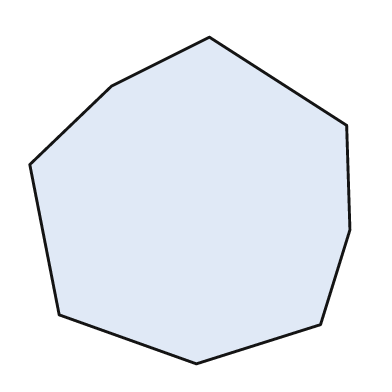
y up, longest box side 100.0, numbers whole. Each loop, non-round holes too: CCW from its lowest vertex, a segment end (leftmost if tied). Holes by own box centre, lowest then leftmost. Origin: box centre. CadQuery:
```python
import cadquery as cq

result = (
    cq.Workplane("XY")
    .moveTo(2.0, -50.0)
    .lineTo(40.0, -38.0)
    .lineTo(49.0, -9.0)
    .lineTo(48.0, 23.0)
    .lineTo(6.0, 50.0)
    .lineTo(-24.0, 35.0)
    .lineTo(-49.0, 11.0)
    .lineTo(-40.0, -35.0)
    .close()
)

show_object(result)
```